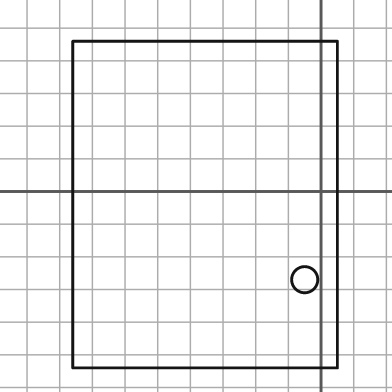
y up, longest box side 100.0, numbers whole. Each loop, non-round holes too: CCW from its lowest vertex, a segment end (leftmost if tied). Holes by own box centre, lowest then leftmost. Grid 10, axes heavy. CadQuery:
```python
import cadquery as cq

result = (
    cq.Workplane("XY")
    .moveTo(-76.0, -54.0)
    .lineTo(5.0, -54.0)
    .lineTo(5.0, 46.0)
    .lineTo(-76.0, 46.0)
    .close()
    .moveTo(-5.0, -27.0)
    .circle(4.0)
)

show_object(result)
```